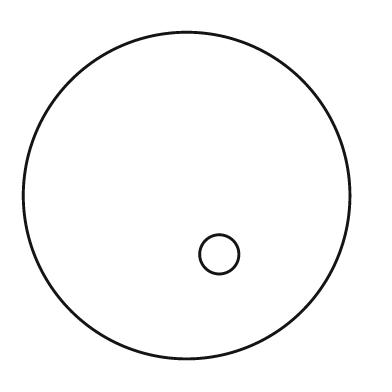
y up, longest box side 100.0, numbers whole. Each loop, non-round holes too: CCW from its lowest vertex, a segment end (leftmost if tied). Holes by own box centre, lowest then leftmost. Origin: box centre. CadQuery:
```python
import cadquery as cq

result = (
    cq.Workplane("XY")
    .moveTo(0.0, 0.0)
    .circle(50.0)
    .moveTo(10.0, -18.0)
    .circle(6.0)
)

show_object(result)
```